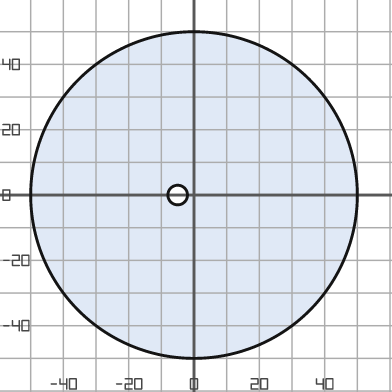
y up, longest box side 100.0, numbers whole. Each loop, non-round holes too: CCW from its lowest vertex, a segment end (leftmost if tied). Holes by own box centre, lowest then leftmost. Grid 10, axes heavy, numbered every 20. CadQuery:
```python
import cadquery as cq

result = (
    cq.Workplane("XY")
    .moveTo(0.0, 0.0)
    .circle(50.0)
    .moveTo(-5.0, 0.0)
    .circle(3.0)
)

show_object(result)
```